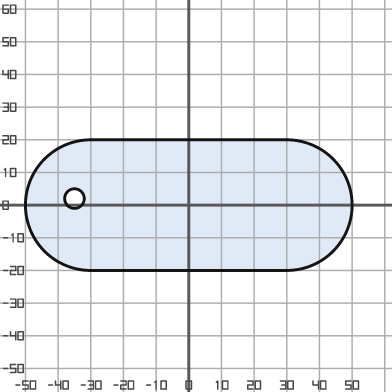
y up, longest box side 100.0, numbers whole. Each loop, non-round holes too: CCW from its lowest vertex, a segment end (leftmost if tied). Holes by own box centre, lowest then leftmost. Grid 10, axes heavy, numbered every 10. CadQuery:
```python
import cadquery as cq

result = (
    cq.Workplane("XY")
    .moveTo(-30.0, -20.0)
    .lineTo(30.0, -20.0)
    .threePointArc((50.0, 0.0), (30.0, 20.0))
    .lineTo(-30.0, 20.0)
    .threePointArc((-50.0, 0.0), (-30.0, -20.0))
    .close()
    .moveTo(-35.0, 2.0)
    .circle(3.0)
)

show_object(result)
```